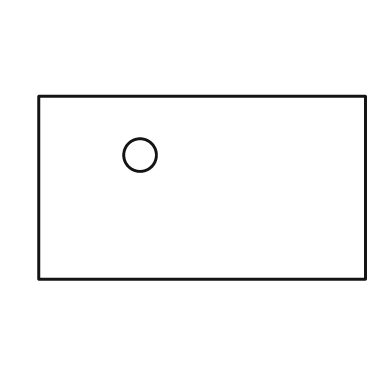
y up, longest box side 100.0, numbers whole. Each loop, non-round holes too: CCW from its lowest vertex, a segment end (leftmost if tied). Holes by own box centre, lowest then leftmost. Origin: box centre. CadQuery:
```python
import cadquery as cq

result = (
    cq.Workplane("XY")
    .moveTo(-50.0, -28.0)
    .lineTo(50.0, -28.0)
    .lineTo(50.0, 28.0)
    .lineTo(-50.0, 28.0)
    .close()
    .moveTo(-19.0, 10.0)
    .circle(5.0)
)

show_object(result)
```